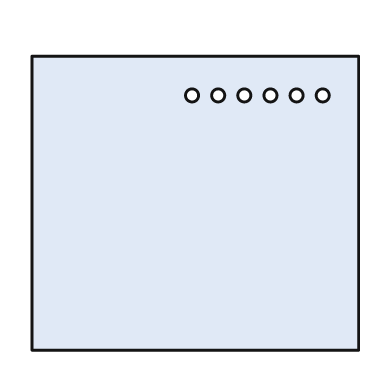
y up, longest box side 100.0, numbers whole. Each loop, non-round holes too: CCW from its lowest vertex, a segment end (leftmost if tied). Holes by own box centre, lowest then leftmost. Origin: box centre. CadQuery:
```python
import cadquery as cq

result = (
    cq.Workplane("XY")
    .moveTo(-50.0, -45.0)
    .lineTo(50.0, -45.0)
    .lineTo(50.0, 45.0)
    .lineTo(-50.0, 45.0)
    .close()
    .moveTo(-1.0, 33.0)
    .circle(2.0)
    .moveTo(7.0, 33.0)
    .circle(2.0)
    .moveTo(15.0, 33.0)
    .circle(2.0)
    .moveTo(23.0, 33.0)
    .circle(2.0)
    .moveTo(31.0, 33.0)
    .circle(2.0)
    .moveTo(39.0, 33.0)
    .circle(2.0)
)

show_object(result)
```